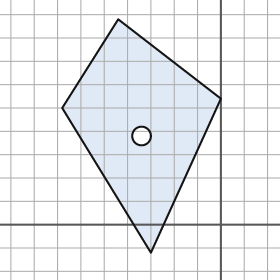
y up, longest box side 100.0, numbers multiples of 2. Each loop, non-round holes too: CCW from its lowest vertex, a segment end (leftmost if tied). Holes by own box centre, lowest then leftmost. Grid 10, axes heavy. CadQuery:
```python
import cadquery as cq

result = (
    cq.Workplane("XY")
    .moveTo(-30.0, -12.0)
    .lineTo(0.0, 54.0)
    .lineTo(-44.0, 88.0)
    .lineTo(-68.0, 50.0)
    .close()
    .moveTo(-34.0, 38.0)
    .circle(4.0)
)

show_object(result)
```